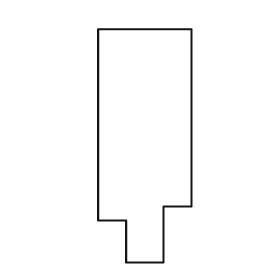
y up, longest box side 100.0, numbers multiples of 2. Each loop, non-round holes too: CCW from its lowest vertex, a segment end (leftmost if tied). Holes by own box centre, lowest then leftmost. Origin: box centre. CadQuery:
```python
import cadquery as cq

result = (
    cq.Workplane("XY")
    .moveTo(-8.0, -50.0)
    .lineTo(8.0, -50.0)
    .lineTo(8.0, -26.0)
    .lineTo(20.0, -26.0)
    .lineTo(20.0, 50.0)
    .lineTo(-20.0, 50.0)
    .lineTo(-20.0, -32.0)
    .lineTo(-8.0, -32.0)
    .close()
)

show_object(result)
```